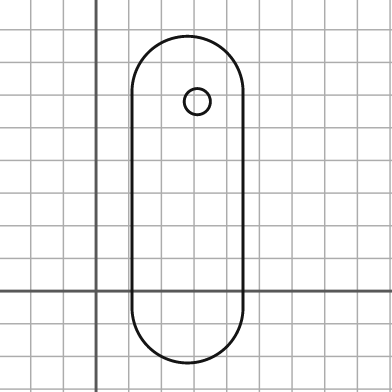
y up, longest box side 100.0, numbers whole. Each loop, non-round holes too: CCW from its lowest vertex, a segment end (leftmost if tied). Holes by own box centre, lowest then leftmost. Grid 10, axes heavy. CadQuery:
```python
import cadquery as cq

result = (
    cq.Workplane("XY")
    .moveTo(11.0, -5.0)
    .threePointArc((28.0, -22.0), (45.0, -5.0))
    .lineTo(45.0, 61.0)
    .threePointArc((28.0, 78.0), (11.0, 61.0))
    .close()
    .moveTo(31.0, 58.0)
    .circle(4.0)
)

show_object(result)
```